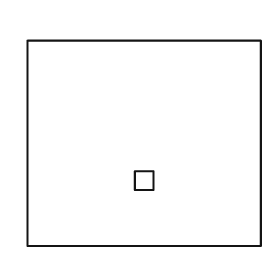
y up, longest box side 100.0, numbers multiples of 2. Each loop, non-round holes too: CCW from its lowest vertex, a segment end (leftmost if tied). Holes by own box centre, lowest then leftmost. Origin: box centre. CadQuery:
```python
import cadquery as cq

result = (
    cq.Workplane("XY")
    .moveTo(-50.0, -44.0)
    .lineTo(50.0, -44.0)
    .lineTo(50.0, 44.0)
    .lineTo(-50.0, 44.0)
    .close()
    .moveTo(-4.0, -20.0)
    .lineTo(4.0, -20.0)
    .lineTo(4.0, -12.0)
    .lineTo(-4.0, -12.0)
    .close()
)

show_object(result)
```